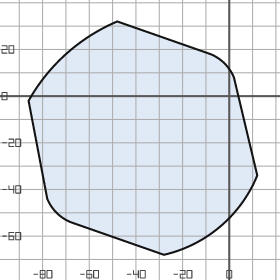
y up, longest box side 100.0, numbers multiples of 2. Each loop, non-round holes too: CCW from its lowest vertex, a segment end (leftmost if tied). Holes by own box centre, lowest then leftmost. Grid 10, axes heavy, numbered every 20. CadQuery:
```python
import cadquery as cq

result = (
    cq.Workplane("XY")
    .moveTo(-28.0, -68.0)
    .threePointArc((-4.0, -56.0), (12.0, -34.0))
    .lineTo(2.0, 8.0)
    .threePointArc((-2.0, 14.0), (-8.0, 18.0))
    .lineTo(-48.0, 32.0)
    .threePointArc((-70.0, 18.0), (-86.0, -2.0))
    .lineTo(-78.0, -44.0)
    .threePointArc((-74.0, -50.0), (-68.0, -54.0))
    .close()
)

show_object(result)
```